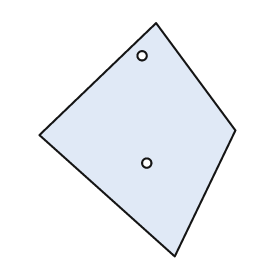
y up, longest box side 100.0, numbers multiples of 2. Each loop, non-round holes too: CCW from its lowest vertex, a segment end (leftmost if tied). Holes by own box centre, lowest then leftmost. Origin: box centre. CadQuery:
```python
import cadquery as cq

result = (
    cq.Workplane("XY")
    .moveTo(16.0, -50.0)
    .lineTo(42.0, 4.0)
    .lineTo(8.0, 50.0)
    .lineTo(-42.0, 2.0)
    .close()
    .moveTo(4.0, -10.0)
    .circle(2.0)
    .moveTo(2.0, 36.0)
    .circle(2.0)
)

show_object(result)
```